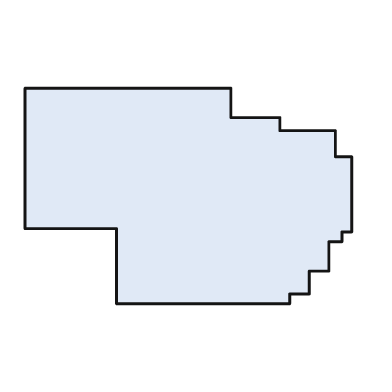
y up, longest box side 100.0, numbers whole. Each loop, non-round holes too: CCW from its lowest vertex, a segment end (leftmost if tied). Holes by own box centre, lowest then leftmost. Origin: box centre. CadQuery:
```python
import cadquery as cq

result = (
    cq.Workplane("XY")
    .moveTo(-22.0, -33.0)
    .lineTo(31.0, -33.0)
    .lineTo(31.0, -30.0)
    .lineTo(37.0, -30.0)
    .lineTo(37.0, -23.0)
    .lineTo(43.0, -23.0)
    .lineTo(43.0, -14.0)
    .lineTo(47.0, -14.0)
    .lineTo(47.0, -11.0)
    .lineTo(50.0, -11.0)
    .lineTo(50.0, 12.0)
    .lineTo(45.0, 12.0)
    .lineTo(45.0, 20.0)
    .lineTo(28.0, 20.0)
    .lineTo(28.0, 24.0)
    .lineTo(13.0, 24.0)
    .lineTo(13.0, 33.0)
    .lineTo(-50.0, 33.0)
    .lineTo(-50.0, -10.0)
    .lineTo(-22.0, -10.0)
    .close()
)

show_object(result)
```